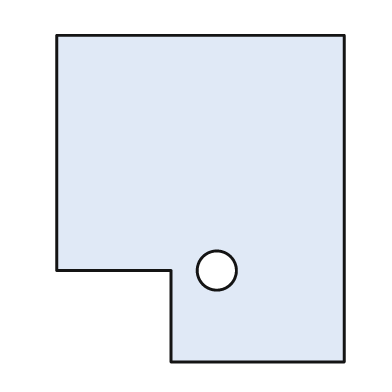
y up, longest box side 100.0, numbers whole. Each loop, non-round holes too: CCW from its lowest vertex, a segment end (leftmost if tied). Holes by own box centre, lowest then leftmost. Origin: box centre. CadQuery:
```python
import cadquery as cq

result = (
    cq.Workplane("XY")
    .moveTo(-9.0, -50.0)
    .lineTo(44.0, -50.0)
    .lineTo(44.0, 50.0)
    .lineTo(-44.0, 50.0)
    .lineTo(-44.0, -22.0)
    .lineTo(-9.0, -22.0)
    .close()
    .moveTo(5.0, -22.0)
    .circle(6.0)
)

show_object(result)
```